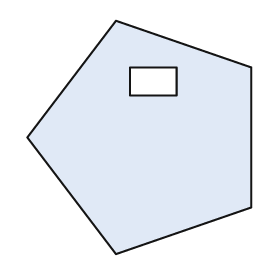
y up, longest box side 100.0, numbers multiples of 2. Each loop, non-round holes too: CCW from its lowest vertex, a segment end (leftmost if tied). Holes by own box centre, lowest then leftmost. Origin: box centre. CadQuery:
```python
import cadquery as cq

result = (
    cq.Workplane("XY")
    .moveTo(-10.0, -50.0)
    .lineTo(48.0, -30.0)
    .lineTo(48.0, 30.0)
    .lineTo(-10.0, 50.0)
    .lineTo(-48.0, 0.0)
    .close()
    .moveTo(-4.0, 18.0)
    .lineTo(16.0, 18.0)
    .lineTo(16.0, 30.0)
    .lineTo(-4.0, 30.0)
    .close()
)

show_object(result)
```